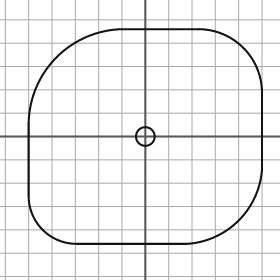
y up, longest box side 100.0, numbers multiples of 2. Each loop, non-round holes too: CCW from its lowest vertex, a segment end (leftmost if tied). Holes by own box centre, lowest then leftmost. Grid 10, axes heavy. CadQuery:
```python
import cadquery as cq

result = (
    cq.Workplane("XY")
    .moveTo(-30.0, -46.0)
    .lineTo(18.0, -46.0)
    .threePointArc((40.0, -36.0), (50.0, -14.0))
    .lineTo(50.0, 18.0)
    .threePointArc((42.0, 38.0), (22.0, 46.0))
    .lineTo(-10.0, 46.0)
    .threePointArc((-38.0, 34.0), (-50.0, 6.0))
    .lineTo(-50.0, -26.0)
    .threePointArc((-44.0, -40.0), (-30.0, -46.0))
    .close()
    .moveTo(0.0, 0.0)
    .circle(4.0)
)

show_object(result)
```